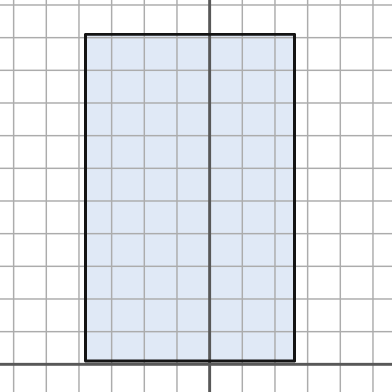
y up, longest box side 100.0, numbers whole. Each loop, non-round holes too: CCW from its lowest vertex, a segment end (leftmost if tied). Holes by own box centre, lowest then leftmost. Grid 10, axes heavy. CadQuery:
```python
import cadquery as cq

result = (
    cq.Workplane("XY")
    .moveTo(-38.0, 1.0)
    .lineTo(26.0, 1.0)
    .lineTo(26.0, 101.0)
    .lineTo(-38.0, 101.0)
    .close()
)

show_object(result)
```